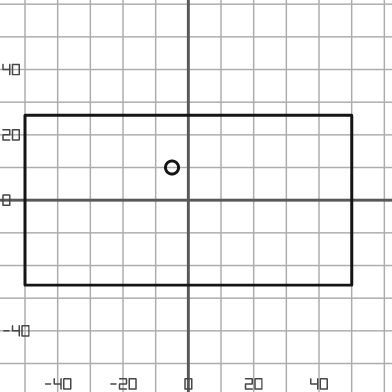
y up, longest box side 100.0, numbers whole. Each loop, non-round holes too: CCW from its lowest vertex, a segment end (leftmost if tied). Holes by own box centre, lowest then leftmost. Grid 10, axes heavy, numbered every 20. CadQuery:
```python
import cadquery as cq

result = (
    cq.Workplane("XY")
    .moveTo(-50.0, -26.0)
    .lineTo(50.0, -26.0)
    .lineTo(50.0, 26.0)
    .lineTo(-50.0, 26.0)
    .close()
    .moveTo(-5.0, 10.0)
    .circle(2.0)
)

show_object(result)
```